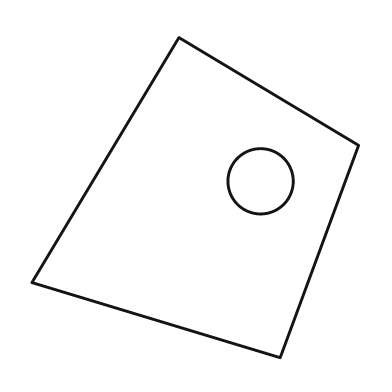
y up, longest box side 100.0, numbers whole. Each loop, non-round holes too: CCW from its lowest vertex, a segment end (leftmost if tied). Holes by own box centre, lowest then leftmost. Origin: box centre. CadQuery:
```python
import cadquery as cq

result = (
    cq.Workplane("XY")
    .moveTo(26.0, -49.0)
    .lineTo(50.0, 16.0)
    .lineTo(-5.0, 49.0)
    .lineTo(-50.0, -26.0)
    .close()
    .moveTo(20.0, 5.0)
    .circle(10.0)
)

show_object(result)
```